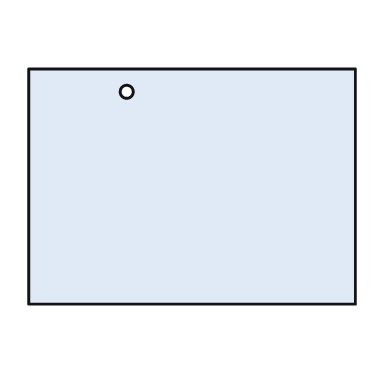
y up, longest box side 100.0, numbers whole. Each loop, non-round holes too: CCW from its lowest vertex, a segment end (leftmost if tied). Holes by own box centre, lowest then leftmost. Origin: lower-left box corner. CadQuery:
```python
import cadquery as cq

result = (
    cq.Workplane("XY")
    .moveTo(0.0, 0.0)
    .lineTo(100.0, 0.0)
    .lineTo(100.0, 72.0)
    .lineTo(0.0, 72.0)
    .close()
    .moveTo(30.0, 65.0)
    .circle(2.0)
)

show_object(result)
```